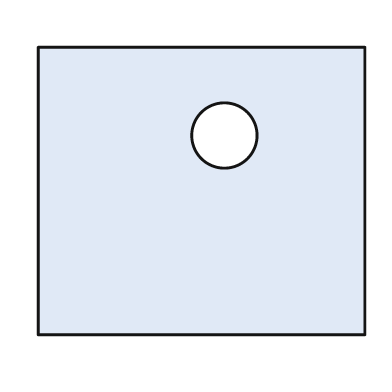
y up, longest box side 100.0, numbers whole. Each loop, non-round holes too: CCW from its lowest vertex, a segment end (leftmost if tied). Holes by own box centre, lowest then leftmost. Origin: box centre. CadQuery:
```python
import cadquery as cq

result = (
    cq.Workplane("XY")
    .moveTo(-50.0, -44.0)
    .lineTo(50.0, -44.0)
    .lineTo(50.0, 44.0)
    .lineTo(-50.0, 44.0)
    .close()
    .moveTo(7.0, 17.0)
    .circle(10.0)
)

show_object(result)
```